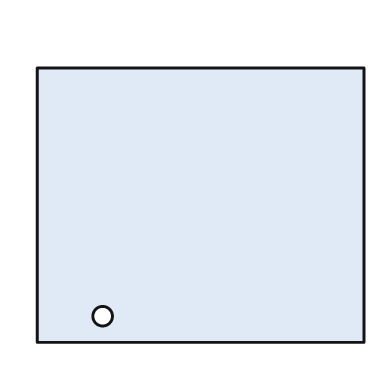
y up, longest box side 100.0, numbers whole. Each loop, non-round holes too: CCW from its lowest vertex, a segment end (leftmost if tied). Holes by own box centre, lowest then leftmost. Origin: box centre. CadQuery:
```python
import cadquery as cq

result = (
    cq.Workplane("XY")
    .moveTo(-50.0, -42.0)
    .lineTo(50.0, -42.0)
    .lineTo(50.0, 42.0)
    .lineTo(-50.0, 42.0)
    .close()
    .moveTo(-30.0, -34.0)
    .circle(3.0)
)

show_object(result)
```